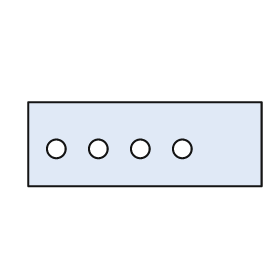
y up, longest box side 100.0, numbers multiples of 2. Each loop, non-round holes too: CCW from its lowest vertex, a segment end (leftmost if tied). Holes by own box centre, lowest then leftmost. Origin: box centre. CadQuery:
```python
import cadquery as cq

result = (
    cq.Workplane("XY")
    .moveTo(-50.0, -18.0)
    .lineTo(50.0, -18.0)
    .lineTo(50.0, 18.0)
    .lineTo(-50.0, 18.0)
    .close()
    .moveTo(-38.0, -2.0)
    .circle(4.0)
    .moveTo(-20.0, -2.0)
    .circle(4.0)
    .moveTo(-2.0, -2.0)
    .circle(4.0)
    .moveTo(16.0, -2.0)
    .circle(4.0)
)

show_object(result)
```